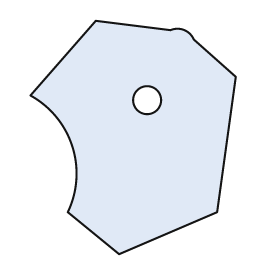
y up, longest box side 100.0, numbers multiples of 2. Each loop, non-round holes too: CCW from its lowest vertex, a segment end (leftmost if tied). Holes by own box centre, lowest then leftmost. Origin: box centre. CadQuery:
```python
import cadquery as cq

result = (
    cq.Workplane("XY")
    .moveTo(-6.0, -50.0)
    .lineTo(36.0, -32.0)
    .lineTo(44.0, 26.0)
    .lineTo(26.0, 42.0)
    .threePointArc((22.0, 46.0), (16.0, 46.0))
    .lineTo(-16.0, 50.0)
    .lineTo(-44.0, 18.0)
    .threePointArc((-26.0, -4.0), (-28.0, -32.0))
    .close()
    .moveTo(6.0, 16.0)
    .circle(6.0)
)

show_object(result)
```